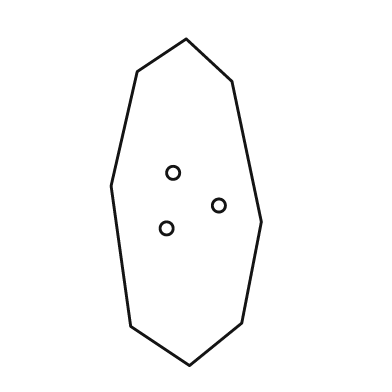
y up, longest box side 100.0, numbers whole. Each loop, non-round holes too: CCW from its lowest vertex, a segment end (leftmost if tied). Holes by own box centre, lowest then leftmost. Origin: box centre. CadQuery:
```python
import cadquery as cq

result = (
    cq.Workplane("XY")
    .moveTo(1.0, -50.0)
    .lineTo(17.0, -37.0)
    .lineTo(23.0, -6.0)
    .lineTo(14.0, 37.0)
    .lineTo(0.0, 50.0)
    .lineTo(-15.0, 40.0)
    .lineTo(-23.0, 5.0)
    .lineTo(-17.0, -38.0)
    .close()
    .moveTo(-6.0, -8.0)
    .circle(2.0)
    .moveTo(10.0, -1.0)
    .circle(2.0)
    .moveTo(-4.0, 9.0)
    .circle(2.0)
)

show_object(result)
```